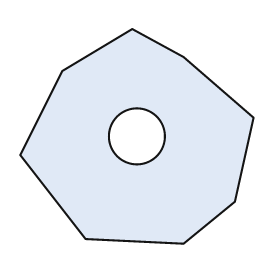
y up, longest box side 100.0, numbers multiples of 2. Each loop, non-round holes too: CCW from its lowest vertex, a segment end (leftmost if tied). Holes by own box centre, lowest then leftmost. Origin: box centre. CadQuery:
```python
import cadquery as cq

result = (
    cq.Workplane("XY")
    .moveTo(20.0, -46.0)
    .lineTo(42.0, -28.0)
    .lineTo(50.0, 8.0)
    .lineTo(20.0, 34.0)
    .lineTo(-2.0, 46.0)
    .lineTo(-32.0, 28.0)
    .lineTo(-50.0, -8.0)
    .lineTo(-22.0, -44.0)
    .close()
    .moveTo(0.0, 0.0)
    .circle(12.0)
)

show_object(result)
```